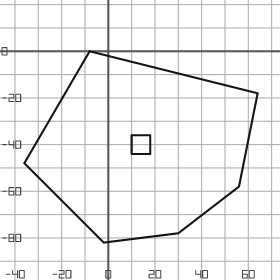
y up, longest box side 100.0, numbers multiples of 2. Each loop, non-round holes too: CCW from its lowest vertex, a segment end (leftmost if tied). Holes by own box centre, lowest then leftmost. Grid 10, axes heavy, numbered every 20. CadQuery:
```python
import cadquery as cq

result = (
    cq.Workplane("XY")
    .moveTo(-2.0, -82.0)
    .lineTo(30.0, -78.0)
    .lineTo(56.0, -58.0)
    .lineTo(64.0, -18.0)
    .lineTo(-8.0, 0.0)
    .lineTo(-36.0, -48.0)
    .close()
    .moveTo(10.0, -44.0)
    .lineTo(18.0, -44.0)
    .lineTo(18.0, -36.0)
    .lineTo(10.0, -36.0)
    .close()
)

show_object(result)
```